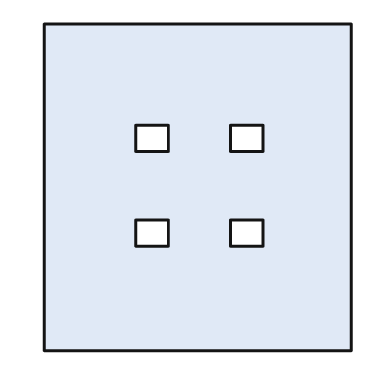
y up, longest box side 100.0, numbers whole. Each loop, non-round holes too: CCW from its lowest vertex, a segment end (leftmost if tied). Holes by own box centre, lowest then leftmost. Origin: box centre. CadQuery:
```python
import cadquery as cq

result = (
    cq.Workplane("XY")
    .moveTo(-47.0, -50.0)
    .lineTo(47.0, -50.0)
    .lineTo(47.0, 50.0)
    .lineTo(-47.0, 50.0)
    .close()
    .moveTo(-19.0, -18.0)
    .lineTo(-9.0, -18.0)
    .lineTo(-9.0, -10.0)
    .lineTo(-19.0, -10.0)
    .close()
    .moveTo(10.0, -18.0)
    .lineTo(20.0, -18.0)
    .lineTo(20.0, -10.0)
    .lineTo(10.0, -10.0)
    .close()
    .moveTo(-19.0, 11.0)
    .lineTo(-9.0, 11.0)
    .lineTo(-9.0, 19.0)
    .lineTo(-19.0, 19.0)
    .close()
    .moveTo(10.0, 11.0)
    .lineTo(20.0, 11.0)
    .lineTo(20.0, 19.0)
    .lineTo(10.0, 19.0)
    .close()
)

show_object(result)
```